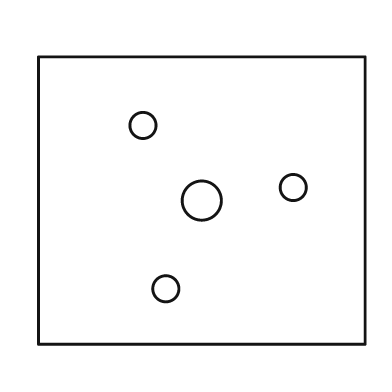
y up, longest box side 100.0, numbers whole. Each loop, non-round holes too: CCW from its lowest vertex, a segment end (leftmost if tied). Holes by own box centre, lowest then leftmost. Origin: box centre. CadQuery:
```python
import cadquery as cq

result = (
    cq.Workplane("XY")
    .moveTo(-50.0, -44.0)
    .lineTo(50.0, -44.0)
    .lineTo(50.0, 44.0)
    .lineTo(-50.0, 44.0)
    .close()
    .moveTo(-11.0, -27.0)
    .circle(4.0)
    .moveTo(0.0, 0.0)
    .circle(6.0)
    .moveTo(28.0, 4.0)
    .circle(4.0)
    .moveTo(-18.0, 23.0)
    .circle(4.0)
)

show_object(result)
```